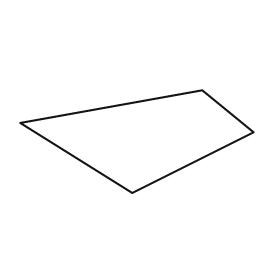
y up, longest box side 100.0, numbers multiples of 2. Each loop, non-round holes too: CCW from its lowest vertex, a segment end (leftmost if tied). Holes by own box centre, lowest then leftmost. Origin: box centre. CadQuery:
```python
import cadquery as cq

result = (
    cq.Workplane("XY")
    .moveTo(-2.0, -22.0)
    .lineTo(50.0, 4.0)
    .lineTo(28.0, 22.0)
    .lineTo(-50.0, 8.0)
    .close()
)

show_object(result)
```